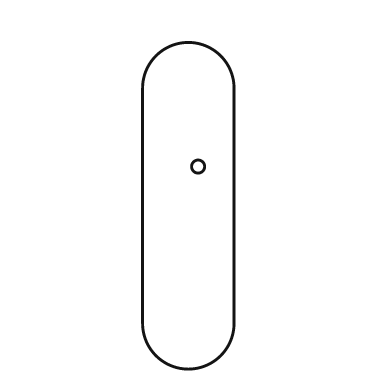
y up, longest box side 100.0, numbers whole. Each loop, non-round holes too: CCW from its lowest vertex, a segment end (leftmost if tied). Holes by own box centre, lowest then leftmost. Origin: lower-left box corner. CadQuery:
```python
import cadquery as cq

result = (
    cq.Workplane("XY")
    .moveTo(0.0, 14.0)
    .threePointArc((14.0, 0.0), (28.0, 14.0))
    .lineTo(28.0, 86.0)
    .threePointArc((14.0, 100.0), (0.0, 86.0))
    .close()
    .moveTo(17.0, 62.0)
    .circle(2.0)
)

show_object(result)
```